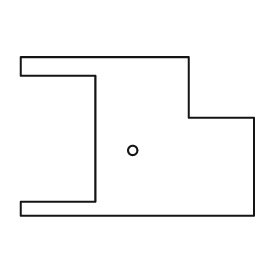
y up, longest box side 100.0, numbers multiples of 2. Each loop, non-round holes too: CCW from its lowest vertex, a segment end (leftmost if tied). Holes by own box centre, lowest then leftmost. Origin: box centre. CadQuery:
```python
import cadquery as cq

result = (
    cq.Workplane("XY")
    .moveTo(-50.0, -34.0)
    .lineTo(50.0, -34.0)
    .lineTo(50.0, 8.0)
    .lineTo(22.0, 8.0)
    .lineTo(22.0, 34.0)
    .lineTo(-50.0, 34.0)
    .lineTo(-50.0, 26.0)
    .lineTo(-18.0, 26.0)
    .lineTo(-18.0, -28.0)
    .lineTo(-50.0, -28.0)
    .close()
    .moveTo(-2.0, -6.0)
    .circle(2.0)
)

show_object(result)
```